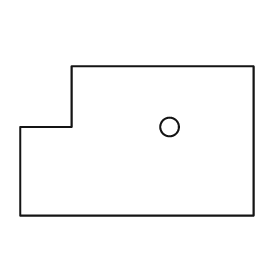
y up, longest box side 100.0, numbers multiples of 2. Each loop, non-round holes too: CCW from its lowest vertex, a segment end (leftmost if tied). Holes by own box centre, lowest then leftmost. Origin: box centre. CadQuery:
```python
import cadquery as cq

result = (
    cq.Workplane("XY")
    .moveTo(-50.0, -32.0)
    .lineTo(50.0, -32.0)
    .lineTo(50.0, 32.0)
    .lineTo(-28.0, 32.0)
    .lineTo(-28.0, 6.0)
    .lineTo(-50.0, 6.0)
    .close()
    .moveTo(14.0, 6.0)
    .circle(4.0)
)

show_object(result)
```